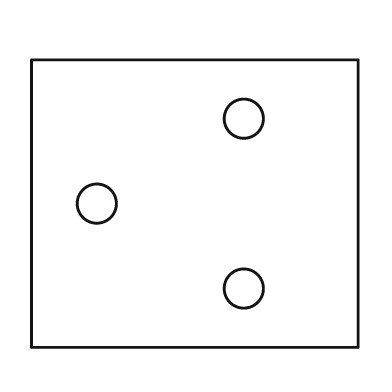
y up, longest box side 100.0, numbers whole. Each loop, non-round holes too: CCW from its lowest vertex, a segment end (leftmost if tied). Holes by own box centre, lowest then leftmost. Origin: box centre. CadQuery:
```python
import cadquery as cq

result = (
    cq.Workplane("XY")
    .moveTo(-50.0, -44.0)
    .lineTo(50.0, -44.0)
    .lineTo(50.0, 44.0)
    .lineTo(-50.0, 44.0)
    .close()
    .moveTo(15.0, -26.0)
    .circle(6.0)
    .moveTo(-30.0, 0.0)
    .circle(6.0)
    .moveTo(15.0, 26.0)
    .circle(6.0)
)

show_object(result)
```